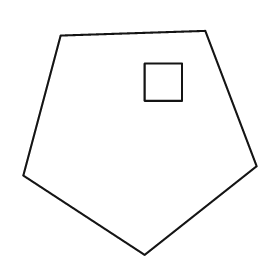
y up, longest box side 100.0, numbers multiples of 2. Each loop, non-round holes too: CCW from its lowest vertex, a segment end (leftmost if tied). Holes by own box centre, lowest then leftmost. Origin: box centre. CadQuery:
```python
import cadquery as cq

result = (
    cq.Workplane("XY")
    .moveTo(2.0, -48.0)
    .lineTo(50.0, -10.0)
    .lineTo(28.0, 48.0)
    .lineTo(-34.0, 46.0)
    .lineTo(-50.0, -14.0)
    .close()
    .moveTo(2.0, 18.0)
    .lineTo(18.0, 18.0)
    .lineTo(18.0, 34.0)
    .lineTo(2.0, 34.0)
    .close()
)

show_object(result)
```